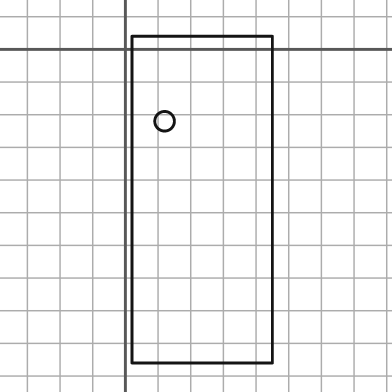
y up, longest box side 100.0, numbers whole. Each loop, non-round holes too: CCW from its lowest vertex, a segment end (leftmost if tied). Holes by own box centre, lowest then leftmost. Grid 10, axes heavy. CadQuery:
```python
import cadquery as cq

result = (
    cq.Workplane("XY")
    .moveTo(2.0, -96.0)
    .lineTo(45.0, -96.0)
    .lineTo(45.0, 4.0)
    .lineTo(2.0, 4.0)
    .close()
    .moveTo(12.0, -22.0)
    .circle(3.0)
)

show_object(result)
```